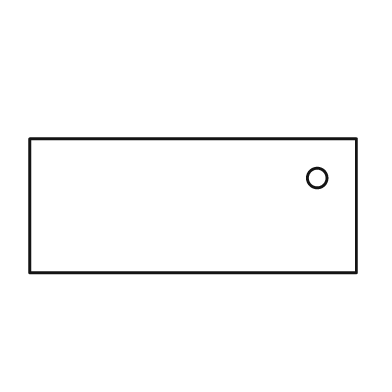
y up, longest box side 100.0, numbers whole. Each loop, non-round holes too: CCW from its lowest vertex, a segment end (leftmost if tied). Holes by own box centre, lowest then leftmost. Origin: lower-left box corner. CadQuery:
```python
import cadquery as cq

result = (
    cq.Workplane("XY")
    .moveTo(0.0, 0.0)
    .lineTo(100.0, 0.0)
    .lineTo(100.0, 41.0)
    .lineTo(0.0, 41.0)
    .close()
    .moveTo(88.0, 29.0)
    .circle(3.0)
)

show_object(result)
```